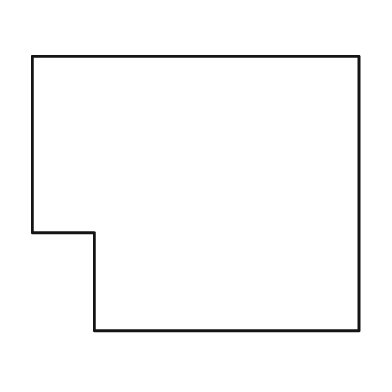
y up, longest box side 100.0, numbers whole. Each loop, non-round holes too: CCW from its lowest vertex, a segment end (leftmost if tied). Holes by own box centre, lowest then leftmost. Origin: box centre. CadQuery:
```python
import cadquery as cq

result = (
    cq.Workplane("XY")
    .moveTo(-31.0, -42.0)
    .lineTo(50.0, -42.0)
    .lineTo(50.0, 42.0)
    .lineTo(-50.0, 42.0)
    .lineTo(-50.0, -12.0)
    .lineTo(-31.0, -12.0)
    .close()
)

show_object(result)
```